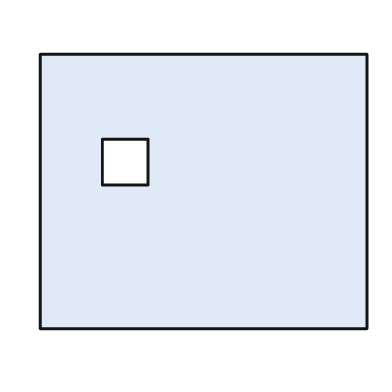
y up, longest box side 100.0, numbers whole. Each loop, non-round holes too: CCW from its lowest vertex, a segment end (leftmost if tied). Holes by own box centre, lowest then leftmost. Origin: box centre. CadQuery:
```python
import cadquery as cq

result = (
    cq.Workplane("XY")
    .moveTo(-50.0, -42.0)
    .lineTo(50.0, -42.0)
    .lineTo(50.0, 42.0)
    .lineTo(-50.0, 42.0)
    .close()
    .moveTo(-31.0, 2.0)
    .lineTo(-17.0, 2.0)
    .lineTo(-17.0, 16.0)
    .lineTo(-31.0, 16.0)
    .close()
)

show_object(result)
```